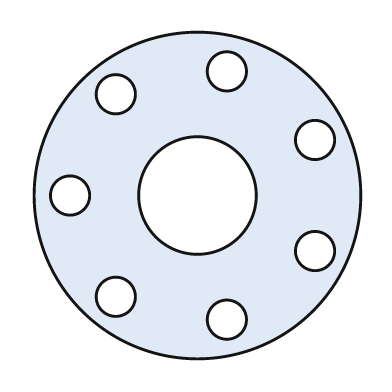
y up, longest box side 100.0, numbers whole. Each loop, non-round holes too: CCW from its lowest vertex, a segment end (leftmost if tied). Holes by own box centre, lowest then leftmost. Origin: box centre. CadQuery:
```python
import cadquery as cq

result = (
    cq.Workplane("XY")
    .moveTo(0.0, 0.0)
    .circle(50.0)
    .moveTo(9.0, -38.0)
    .circle(6.0)
    .moveTo(-25.0, -31.0)
    .circle(6.0)
    .moveTo(36.0, -17.0)
    .circle(6.0)
    .moveTo(-39.0, 0.0)
    .circle(6.0)
    .moveTo(0.0, 0.0)
    .circle(18.0)
    .moveTo(36.0, 17.0)
    .circle(6.0)
    .moveTo(-25.0, 31.0)
    .circle(6.0)
    .moveTo(9.0, 38.0)
    .circle(6.0)
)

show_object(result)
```